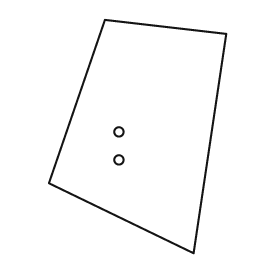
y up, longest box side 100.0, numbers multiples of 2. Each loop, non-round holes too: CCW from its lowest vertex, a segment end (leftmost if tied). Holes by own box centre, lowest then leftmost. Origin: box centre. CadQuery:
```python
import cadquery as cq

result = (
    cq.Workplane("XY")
    .moveTo(24.0, -50.0)
    .lineTo(38.0, 44.0)
    .lineTo(-14.0, 50.0)
    .lineTo(-38.0, -20.0)
    .close()
    .moveTo(-8.0, -10.0)
    .circle(2.0)
    .moveTo(-8.0, 2.0)
    .circle(2.0)
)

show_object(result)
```